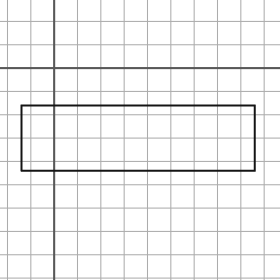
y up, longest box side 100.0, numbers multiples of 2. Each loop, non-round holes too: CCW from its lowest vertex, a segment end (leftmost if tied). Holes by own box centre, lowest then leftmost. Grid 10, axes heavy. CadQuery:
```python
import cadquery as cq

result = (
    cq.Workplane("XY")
    .moveTo(-14.0, -44.0)
    .lineTo(86.0, -44.0)
    .lineTo(86.0, -16.0)
    .lineTo(-14.0, -16.0)
    .close()
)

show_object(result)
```